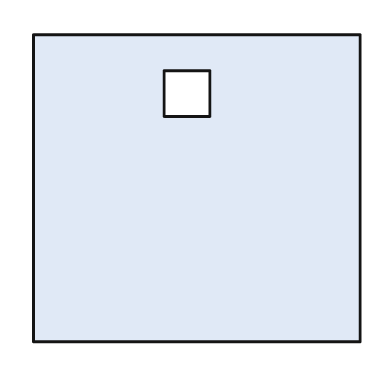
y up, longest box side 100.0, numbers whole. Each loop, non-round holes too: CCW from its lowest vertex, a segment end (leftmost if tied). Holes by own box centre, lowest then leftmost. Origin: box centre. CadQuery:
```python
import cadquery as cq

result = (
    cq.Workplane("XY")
    .moveTo(-50.0, -47.0)
    .lineTo(50.0, -47.0)
    .lineTo(50.0, 47.0)
    .lineTo(-50.0, 47.0)
    .close()
    .moveTo(-10.0, 22.0)
    .lineTo(4.0, 22.0)
    .lineTo(4.0, 36.0)
    .lineTo(-10.0, 36.0)
    .close()
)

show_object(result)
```